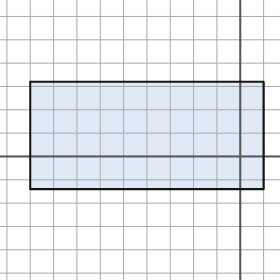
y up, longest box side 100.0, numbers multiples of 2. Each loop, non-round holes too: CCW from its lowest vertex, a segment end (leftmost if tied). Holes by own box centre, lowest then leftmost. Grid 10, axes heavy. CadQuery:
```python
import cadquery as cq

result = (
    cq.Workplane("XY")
    .moveTo(-90.0, -14.0)
    .lineTo(10.0, -14.0)
    .lineTo(10.0, 32.0)
    .lineTo(-90.0, 32.0)
    .close()
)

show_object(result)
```